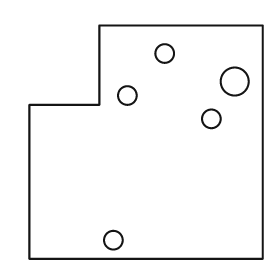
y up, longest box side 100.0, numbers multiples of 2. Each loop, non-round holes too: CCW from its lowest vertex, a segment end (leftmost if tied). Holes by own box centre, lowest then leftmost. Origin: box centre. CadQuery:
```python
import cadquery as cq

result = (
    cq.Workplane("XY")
    .moveTo(-50.0, -50.0)
    .lineTo(50.0, -50.0)
    .lineTo(50.0, 50.0)
    .lineTo(-20.0, 50.0)
    .lineTo(-20.0, 16.0)
    .lineTo(-50.0, 16.0)
    .close()
    .moveTo(-14.0, -42.0)
    .circle(4.0)
    .moveTo(28.0, 10.0)
    .circle(4.0)
    .moveTo(-8.0, 20.0)
    .circle(4.0)
    .moveTo(38.0, 26.0)
    .circle(6.0)
    .moveTo(8.0, 38.0)
    .circle(4.0)
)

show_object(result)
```